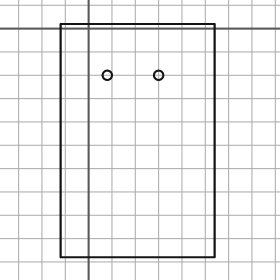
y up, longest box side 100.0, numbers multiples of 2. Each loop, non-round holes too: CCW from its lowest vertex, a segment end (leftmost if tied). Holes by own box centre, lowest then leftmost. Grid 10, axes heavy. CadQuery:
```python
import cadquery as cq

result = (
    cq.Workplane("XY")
    .moveTo(-12.0, -98.0)
    .lineTo(54.0, -98.0)
    .lineTo(54.0, 2.0)
    .lineTo(-12.0, 2.0)
    .close()
    .moveTo(8.0, -20.0)
    .circle(2.0)
    .moveTo(30.0, -20.0)
    .circle(2.0)
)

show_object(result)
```